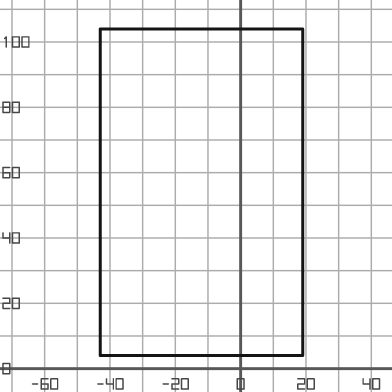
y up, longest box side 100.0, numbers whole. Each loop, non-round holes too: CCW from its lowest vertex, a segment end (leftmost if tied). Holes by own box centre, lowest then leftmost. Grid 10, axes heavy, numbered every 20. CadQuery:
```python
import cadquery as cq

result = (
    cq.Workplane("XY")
    .moveTo(-43.0, 4.0)
    .lineTo(19.0, 4.0)
    .lineTo(19.0, 104.0)
    .lineTo(-43.0, 104.0)
    .close()
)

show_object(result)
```